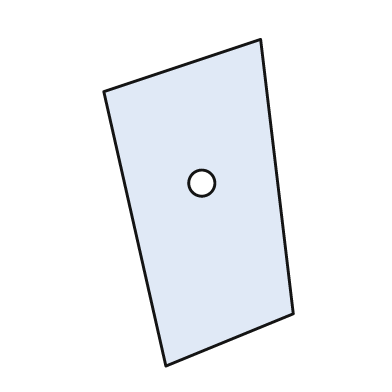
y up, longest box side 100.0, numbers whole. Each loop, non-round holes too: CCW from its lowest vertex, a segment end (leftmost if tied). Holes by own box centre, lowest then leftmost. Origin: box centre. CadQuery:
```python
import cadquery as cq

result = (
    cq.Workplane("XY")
    .moveTo(-10.0, -50.0)
    .lineTo(29.0, -34.0)
    .lineTo(19.0, 50.0)
    .lineTo(-29.0, 34.0)
    .close()
    .moveTo(1.0, 6.0)
    .circle(4.0)
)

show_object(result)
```